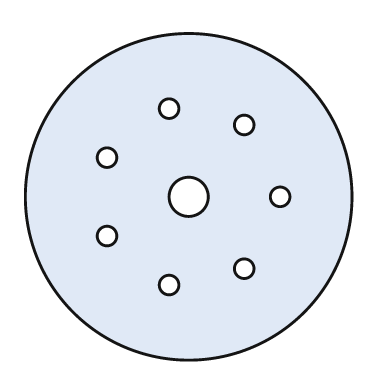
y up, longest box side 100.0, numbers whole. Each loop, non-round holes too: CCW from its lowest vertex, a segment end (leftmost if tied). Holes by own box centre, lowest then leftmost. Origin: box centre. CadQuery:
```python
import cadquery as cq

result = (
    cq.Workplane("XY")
    .moveTo(0.0, 0.0)
    .circle(50.0)
    .moveTo(-6.0, -27.0)
    .circle(3.0)
    .moveTo(17.0, -22.0)
    .circle(3.0)
    .moveTo(-25.0, -12.0)
    .circle(3.0)
    .moveTo(0.0, 0.0)
    .circle(6.0)
    .moveTo(28.0, 0.0)
    .circle(3.0)
    .moveTo(-25.0, 12.0)
    .circle(3.0)
    .moveTo(17.0, 22.0)
    .circle(3.0)
    .moveTo(-6.0, 27.0)
    .circle(3.0)
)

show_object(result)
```